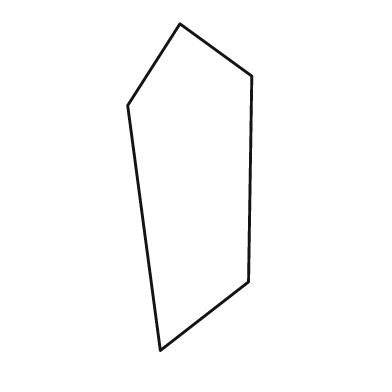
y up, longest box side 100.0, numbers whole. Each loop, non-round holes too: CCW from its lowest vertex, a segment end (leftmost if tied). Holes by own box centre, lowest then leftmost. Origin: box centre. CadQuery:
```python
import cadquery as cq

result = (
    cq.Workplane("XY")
    .moveTo(-9.0, -50.0)
    .lineTo(18.0, -29.0)
    .lineTo(19.0, 34.0)
    .lineTo(-3.0, 50.0)
    .lineTo(-19.0, 25.0)
    .close()
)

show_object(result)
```